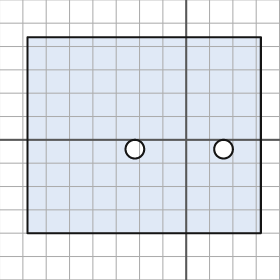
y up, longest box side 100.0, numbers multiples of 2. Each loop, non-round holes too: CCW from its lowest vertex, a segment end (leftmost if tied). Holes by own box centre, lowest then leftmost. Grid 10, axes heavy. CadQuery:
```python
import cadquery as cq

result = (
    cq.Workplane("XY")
    .moveTo(-68.0, -40.0)
    .lineTo(32.0, -40.0)
    .lineTo(32.0, 44.0)
    .lineTo(-68.0, 44.0)
    .close()
    .moveTo(-22.0, -4.0)
    .circle(4.0)
    .moveTo(16.0, -4.0)
    .circle(4.0)
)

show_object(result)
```